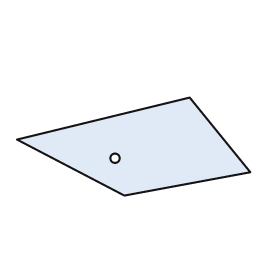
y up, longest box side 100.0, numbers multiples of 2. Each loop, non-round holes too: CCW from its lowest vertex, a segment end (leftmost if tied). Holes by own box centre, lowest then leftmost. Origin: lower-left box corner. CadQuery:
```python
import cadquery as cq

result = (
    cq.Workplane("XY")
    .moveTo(46.0, 0.0)
    .lineTo(100.0, 10.0)
    .lineTo(74.0, 42.0)
    .lineTo(0.0, 24.0)
    .close()
    .moveTo(42.0, 16.0)
    .circle(2.0)
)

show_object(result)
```